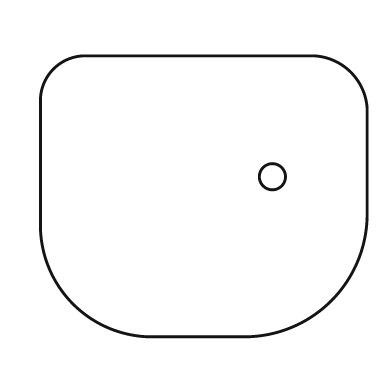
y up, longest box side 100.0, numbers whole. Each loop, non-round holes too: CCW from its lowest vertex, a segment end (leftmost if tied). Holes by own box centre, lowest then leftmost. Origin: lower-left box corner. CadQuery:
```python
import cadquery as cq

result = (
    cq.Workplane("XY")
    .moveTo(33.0, 0.0)
    .lineTo(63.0, 0.0)
    .threePointArc((89.0, 11.0), (100.0, 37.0))
    .lineTo(100.0, 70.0)
    .threePointArc((95.0, 81.0), (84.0, 86.0))
    .lineTo(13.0, 86.0)
    .threePointArc((4.0, 82.0), (0.0, 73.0))
    .lineTo(0.0, 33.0)
    .threePointArc((10.0, 10.0), (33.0, 0.0))
    .close()
    .moveTo(71.0, 49.0)
    .circle(4.0)
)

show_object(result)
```